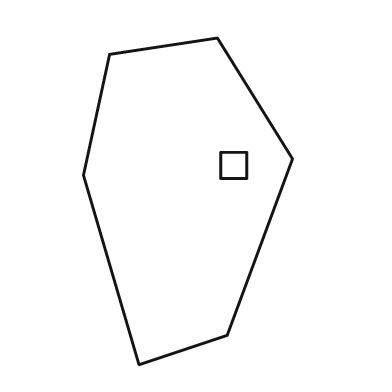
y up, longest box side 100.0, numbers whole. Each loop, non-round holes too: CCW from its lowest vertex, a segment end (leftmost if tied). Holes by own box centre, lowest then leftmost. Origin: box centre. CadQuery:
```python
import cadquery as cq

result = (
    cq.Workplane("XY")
    .moveTo(-15.0, -50.0)
    .lineTo(12.0, -41.0)
    .lineTo(32.0, 13.0)
    .lineTo(9.0, 50.0)
    .lineTo(-24.0, 45.0)
    .lineTo(-32.0, 8.0)
    .close()
    .moveTo(10.0, 7.0)
    .lineTo(18.0, 7.0)
    .lineTo(18.0, 15.0)
    .lineTo(10.0, 15.0)
    .close()
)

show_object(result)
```